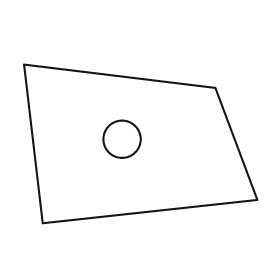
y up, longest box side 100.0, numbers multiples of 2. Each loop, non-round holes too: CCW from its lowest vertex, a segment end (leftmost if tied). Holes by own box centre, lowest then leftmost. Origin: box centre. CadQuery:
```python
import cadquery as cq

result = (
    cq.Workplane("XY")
    .moveTo(-42.0, -34.0)
    .lineTo(50.0, -24.0)
    .lineTo(32.0, 24.0)
    .lineTo(-50.0, 34.0)
    .close()
    .moveTo(-8.0, 2.0)
    .circle(8.0)
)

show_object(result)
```